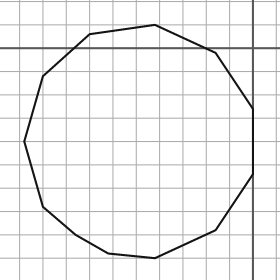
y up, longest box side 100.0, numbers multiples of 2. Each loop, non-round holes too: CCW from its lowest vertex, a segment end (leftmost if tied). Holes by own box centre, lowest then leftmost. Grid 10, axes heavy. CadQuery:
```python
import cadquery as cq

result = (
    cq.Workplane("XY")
    .moveTo(-42.0, -90.0)
    .lineTo(-16.0, -78.0)
    .lineTo(0.0, -54.0)
    .lineTo(0.0, -26.0)
    .lineTo(-16.0, -2.0)
    .lineTo(-42.0, 10.0)
    .lineTo(-70.0, 6.0)
    .lineTo(-90.0, -12.0)
    .lineTo(-98.0, -40.0)
    .lineTo(-90.0, -68.0)
    .lineTo(-76.0, -80.0)
    .lineTo(-62.0, -88.0)
    .close()
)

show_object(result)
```